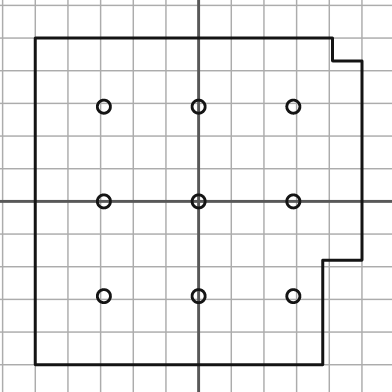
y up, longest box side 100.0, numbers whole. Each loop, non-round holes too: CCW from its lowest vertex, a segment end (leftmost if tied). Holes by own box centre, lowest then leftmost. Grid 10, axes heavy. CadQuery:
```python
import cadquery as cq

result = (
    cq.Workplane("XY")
    .moveTo(-50.0, -50.0)
    .lineTo(38.0, -50.0)
    .lineTo(38.0, -18.0)
    .lineTo(50.0, -18.0)
    .lineTo(50.0, 43.0)
    .lineTo(41.0, 43.0)
    .lineTo(41.0, 50.0)
    .lineTo(-50.0, 50.0)
    .close()
    .moveTo(-29.0, -29.0)
    .circle(2.0)
    .moveTo(0.0, -29.0)
    .circle(2.0)
    .moveTo(29.0, -29.0)
    .circle(2.0)
    .moveTo(-29.0, 0.0)
    .circle(2.0)
    .moveTo(0.0, 0.0)
    .circle(2.0)
    .moveTo(29.0, 0.0)
    .circle(2.0)
    .moveTo(-29.0, 29.0)
    .circle(2.0)
    .moveTo(0.0, 29.0)
    .circle(2.0)
    .moveTo(29.0, 29.0)
    .circle(2.0)
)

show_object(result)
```